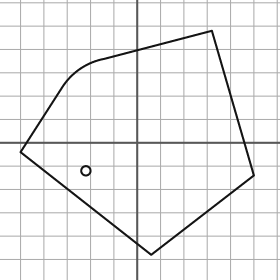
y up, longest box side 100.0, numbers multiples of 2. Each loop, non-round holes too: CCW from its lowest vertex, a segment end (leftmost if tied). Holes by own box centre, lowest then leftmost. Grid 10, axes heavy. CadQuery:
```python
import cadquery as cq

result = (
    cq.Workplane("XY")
    .moveTo(6.0, -48.0)
    .lineTo(50.0, -14.0)
    .lineTo(32.0, 48.0)
    .lineTo(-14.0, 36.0)
    .threePointArc((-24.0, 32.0), (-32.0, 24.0))
    .lineTo(-50.0, -4.0)
    .close()
    .moveTo(-22.0, -12.0)
    .circle(2.0)
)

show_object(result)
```